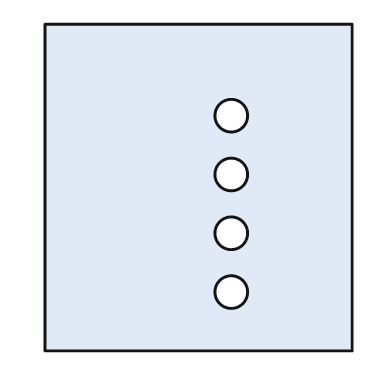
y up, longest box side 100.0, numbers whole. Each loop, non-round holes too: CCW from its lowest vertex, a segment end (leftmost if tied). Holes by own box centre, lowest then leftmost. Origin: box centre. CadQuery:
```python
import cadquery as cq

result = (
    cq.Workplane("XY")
    .moveTo(-47.0, -50.0)
    .lineTo(47.0, -50.0)
    .lineTo(47.0, 50.0)
    .lineTo(-47.0, 50.0)
    .close()
    .moveTo(10.0, -32.0)
    .circle(5.0)
    .moveTo(10.0, -14.0)
    .circle(5.0)
    .moveTo(10.0, 4.0)
    .circle(5.0)
    .moveTo(10.0, 22.0)
    .circle(5.0)
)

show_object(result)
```